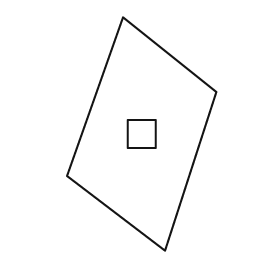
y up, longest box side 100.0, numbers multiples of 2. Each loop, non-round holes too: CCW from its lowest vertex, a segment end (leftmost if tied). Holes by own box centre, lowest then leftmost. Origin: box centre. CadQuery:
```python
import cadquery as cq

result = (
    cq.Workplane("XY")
    .moveTo(10.0, -50.0)
    .lineTo(32.0, 18.0)
    .lineTo(-8.0, 50.0)
    .lineTo(-32.0, -18.0)
    .close()
    .moveTo(-6.0, -6.0)
    .lineTo(6.0, -6.0)
    .lineTo(6.0, 6.0)
    .lineTo(-6.0, 6.0)
    .close()
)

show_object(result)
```